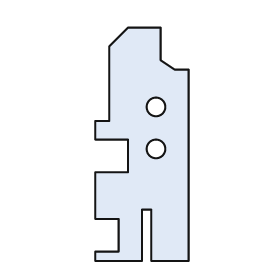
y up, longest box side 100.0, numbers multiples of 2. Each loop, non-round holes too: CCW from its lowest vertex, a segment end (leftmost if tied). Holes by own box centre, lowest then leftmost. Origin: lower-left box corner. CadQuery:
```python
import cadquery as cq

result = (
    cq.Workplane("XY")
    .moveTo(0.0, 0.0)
    .lineTo(20.0, 0.0)
    .lineTo(20.0, 22.0)
    .lineTo(24.0, 22.0)
    .lineTo(24.0, 0.0)
    .lineTo(40.0, 0.0)
    .lineTo(40.0, 82.0)
    .lineTo(34.0, 82.0)
    .lineTo(28.0, 86.0)
    .lineTo(28.0, 100.0)
    .lineTo(14.0, 100.0)
    .lineTo(6.0, 92.0)
    .lineTo(6.0, 60.0)
    .lineTo(0.0, 60.0)
    .lineTo(0.0, 52.0)
    .lineTo(14.0, 52.0)
    .lineTo(14.0, 38.0)
    .lineTo(0.0, 38.0)
    .lineTo(0.0, 18.0)
    .lineTo(10.0, 18.0)
    .lineTo(10.0, 4.0)
    .lineTo(0.0, 4.0)
    .close()
    .moveTo(26.0, 48.0)
    .circle(4.0)
    .moveTo(26.0, 66.0)
    .circle(4.0)
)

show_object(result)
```